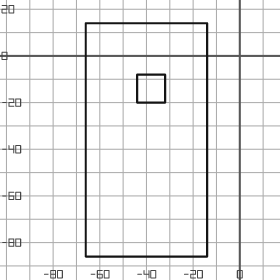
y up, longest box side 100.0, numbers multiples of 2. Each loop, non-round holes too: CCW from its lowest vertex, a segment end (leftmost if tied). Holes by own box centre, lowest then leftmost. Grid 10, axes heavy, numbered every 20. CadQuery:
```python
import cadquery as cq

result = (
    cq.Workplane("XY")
    .moveTo(-66.0, -86.0)
    .lineTo(-14.0, -86.0)
    .lineTo(-14.0, 14.0)
    .lineTo(-66.0, 14.0)
    .close()
    .moveTo(-44.0, -20.0)
    .lineTo(-32.0, -20.0)
    .lineTo(-32.0, -8.0)
    .lineTo(-44.0, -8.0)
    .close()
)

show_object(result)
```